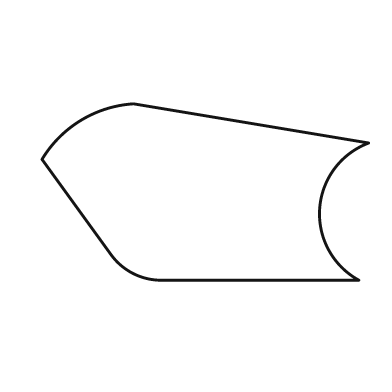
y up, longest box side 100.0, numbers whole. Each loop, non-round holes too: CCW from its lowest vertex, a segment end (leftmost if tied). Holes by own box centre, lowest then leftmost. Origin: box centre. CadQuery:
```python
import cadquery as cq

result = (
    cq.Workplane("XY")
    .moveTo(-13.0, -27.0)
    .lineTo(47.0, -27.0)
    .threePointArc((35.0, -5.0), (50.0, 15.0))
    .lineTo(-22.0, 27.0)
    .threePointArc((-38.0, 22.0), (-50.0, 10.0))
    .lineTo(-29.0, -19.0)
    .threePointArc((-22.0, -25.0), (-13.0, -27.0))
    .close()
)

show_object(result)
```